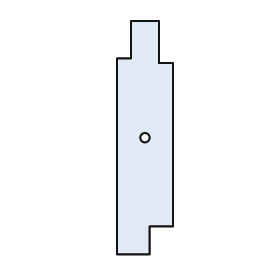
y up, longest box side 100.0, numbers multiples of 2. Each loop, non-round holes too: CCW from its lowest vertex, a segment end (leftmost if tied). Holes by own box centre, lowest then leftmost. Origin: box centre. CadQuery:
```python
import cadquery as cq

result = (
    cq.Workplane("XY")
    .moveTo(-12.0, -50.0)
    .lineTo(2.0, -50.0)
    .lineTo(2.0, -38.0)
    .lineTo(12.0, -38.0)
    .lineTo(12.0, 32.0)
    .lineTo(6.0, 32.0)
    .lineTo(6.0, 50.0)
    .lineTo(-6.0, 50.0)
    .lineTo(-6.0, 34.0)
    .lineTo(-12.0, 34.0)
    .close()
    .moveTo(0.0, 0.0)
    .circle(2.0)
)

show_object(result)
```